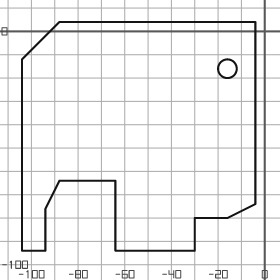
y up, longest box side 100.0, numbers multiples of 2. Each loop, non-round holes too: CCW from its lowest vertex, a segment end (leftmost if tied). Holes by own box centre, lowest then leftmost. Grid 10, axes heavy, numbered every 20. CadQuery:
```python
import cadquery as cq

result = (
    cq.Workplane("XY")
    .moveTo(-104.0, -94.0)
    .lineTo(-94.0, -94.0)
    .lineTo(-94.0, -76.0)
    .lineTo(-88.0, -64.0)
    .lineTo(-64.0, -64.0)
    .lineTo(-64.0, -94.0)
    .lineTo(-30.0, -94.0)
    .lineTo(-30.0, -80.0)
    .lineTo(-16.0, -80.0)
    .lineTo(-4.0, -74.0)
    .lineTo(-4.0, 4.0)
    .lineTo(-88.0, 4.0)
    .lineTo(-104.0, -12.0)
    .close()
    .moveTo(-16.0, -16.0)
    .circle(4.0)
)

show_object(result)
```